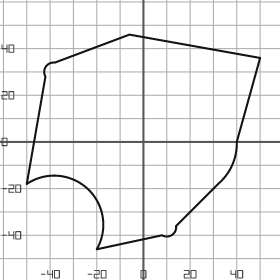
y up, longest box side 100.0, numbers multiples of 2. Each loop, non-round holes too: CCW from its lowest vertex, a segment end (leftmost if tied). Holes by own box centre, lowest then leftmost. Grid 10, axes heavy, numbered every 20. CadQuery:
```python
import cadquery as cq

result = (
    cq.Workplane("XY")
    .moveTo(-20.0, -46.0)
    .lineTo(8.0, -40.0)
    .threePointArc((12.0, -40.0), (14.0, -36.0))
    .lineTo(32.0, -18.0)
    .threePointArc((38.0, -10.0), (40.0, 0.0))
    .lineTo(50.0, 36.0)
    .lineTo(-6.0, 46.0)
    .lineTo(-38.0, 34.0)
    .threePointArc((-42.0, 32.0), (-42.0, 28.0))
    .lineTo(-50.0, -18.0)
    .threePointArc((-24.0, -20.0), (-20.0, -46.0))
    .close()
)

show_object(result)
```